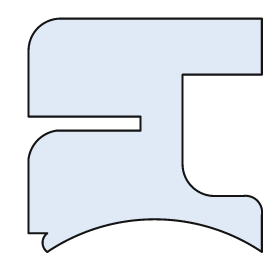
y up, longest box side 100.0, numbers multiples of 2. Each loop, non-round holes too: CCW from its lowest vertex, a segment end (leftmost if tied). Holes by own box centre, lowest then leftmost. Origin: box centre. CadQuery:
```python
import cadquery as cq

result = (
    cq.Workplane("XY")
    .moveTo(-42.0, -50.0)
    .threePointArc((4.0, -36.0), (50.0, -50.0))
    .lineTo(50.0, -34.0)
    .threePointArc((48.0, -28.0), (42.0, -26.0))
    .lineTo(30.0, -26.0)
    .threePointArc((20.0, -22.0), (16.0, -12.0))
    .lineTo(16.0, 26.0)
    .lineTo(50.0, 26.0)
    .lineTo(50.0, 50.0)
    .lineTo(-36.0, 50.0)
    .threePointArc((-46.0, 46.0), (-50.0, 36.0))
    .lineTo(-50.0, 8.0)
    .lineTo(-2.0, 8.0)
    .lineTo(-2.0, 2.0)
    .lineTo(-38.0, 2.0)
    .threePointArc((-46.0, -2.0), (-50.0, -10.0))
    .lineTo(-50.0, -42.0)
    .lineTo(-42.0, -42.0)
    .threePointArc((-44.0, -46.0), (-42.0, -50.0))
    .close()
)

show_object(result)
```